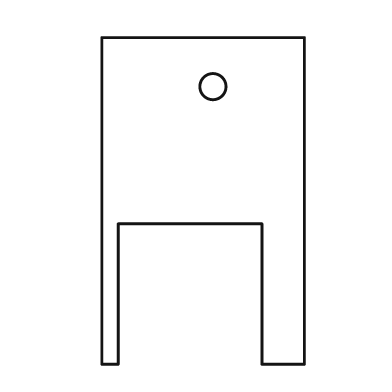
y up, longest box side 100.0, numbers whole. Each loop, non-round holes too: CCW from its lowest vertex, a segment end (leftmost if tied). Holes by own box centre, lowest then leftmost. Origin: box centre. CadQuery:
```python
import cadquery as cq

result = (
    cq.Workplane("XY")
    .moveTo(-31.0, -50.0)
    .lineTo(-26.0, -50.0)
    .lineTo(-26.0, -7.0)
    .lineTo(18.0, -7.0)
    .lineTo(18.0, -50.0)
    .lineTo(31.0, -50.0)
    .lineTo(31.0, 50.0)
    .lineTo(-31.0, 50.0)
    .close()
    .moveTo(3.0, 35.0)
    .circle(4.0)
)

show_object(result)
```